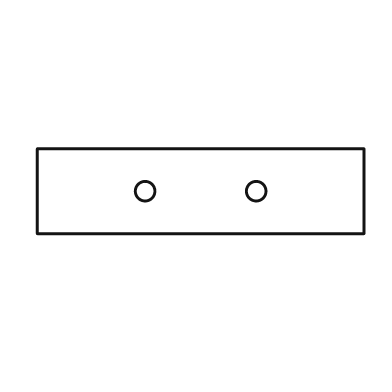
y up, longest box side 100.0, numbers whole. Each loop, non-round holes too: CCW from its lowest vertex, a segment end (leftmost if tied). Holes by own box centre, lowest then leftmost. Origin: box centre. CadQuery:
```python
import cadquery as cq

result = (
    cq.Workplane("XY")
    .moveTo(-50.0, -13.0)
    .lineTo(50.0, -13.0)
    .lineTo(50.0, 13.0)
    .lineTo(-50.0, 13.0)
    .close()
    .moveTo(-17.0, 0.0)
    .circle(3.0)
    .moveTo(17.0, 0.0)
    .circle(3.0)
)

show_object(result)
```